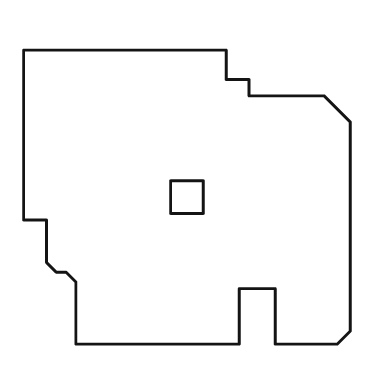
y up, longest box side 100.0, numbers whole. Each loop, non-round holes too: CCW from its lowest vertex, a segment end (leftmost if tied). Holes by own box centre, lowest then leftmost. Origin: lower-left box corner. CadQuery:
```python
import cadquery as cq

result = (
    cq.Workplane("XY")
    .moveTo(16.0, 0.0)
    .lineTo(66.0, 0.0)
    .lineTo(66.0, 17.0)
    .lineTo(77.0, 17.0)
    .lineTo(77.0, 0.0)
    .lineTo(96.0, 0.0)
    .lineTo(100.0, 4.0)
    .lineTo(100.0, 68.0)
    .lineTo(92.0, 76.0)
    .lineTo(69.0, 76.0)
    .lineTo(69.0, 81.0)
    .lineTo(62.0, 81.0)
    .lineTo(62.0, 90.0)
    .lineTo(0.0, 90.0)
    .lineTo(0.0, 38.0)
    .lineTo(7.0, 38.0)
    .lineTo(7.0, 25.0)
    .lineTo(10.0, 22.0)
    .lineTo(13.0, 22.0)
    .lineTo(16.0, 19.0)
    .close()
    .moveTo(45.0, 40.0)
    .lineTo(55.0, 40.0)
    .lineTo(55.0, 50.0)
    .lineTo(45.0, 50.0)
    .close()
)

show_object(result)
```